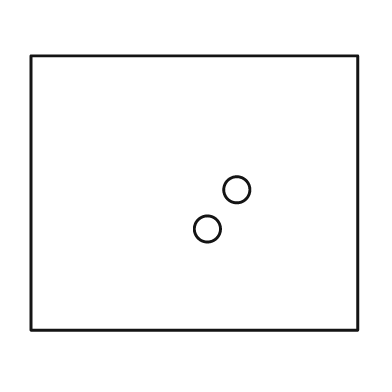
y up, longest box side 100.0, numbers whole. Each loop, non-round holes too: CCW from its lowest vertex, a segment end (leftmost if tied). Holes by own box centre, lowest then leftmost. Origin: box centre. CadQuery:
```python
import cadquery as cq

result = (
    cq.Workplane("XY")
    .moveTo(-50.0, -42.0)
    .lineTo(50.0, -42.0)
    .lineTo(50.0, 42.0)
    .lineTo(-50.0, 42.0)
    .close()
    .moveTo(4.0, -11.0)
    .circle(4.0)
    .moveTo(13.0, 1.0)
    .circle(4.0)
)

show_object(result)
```